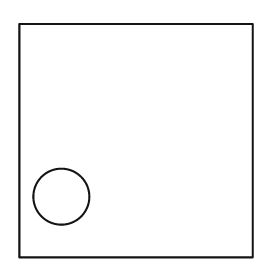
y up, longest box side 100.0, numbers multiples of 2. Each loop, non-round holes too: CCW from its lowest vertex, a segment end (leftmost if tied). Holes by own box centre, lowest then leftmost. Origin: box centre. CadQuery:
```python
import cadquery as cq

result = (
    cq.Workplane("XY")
    .moveTo(-50.0, -50.0)
    .lineTo(50.0, -50.0)
    .lineTo(50.0, 50.0)
    .lineTo(-50.0, 50.0)
    .close()
    .moveTo(-32.0, -24.0)
    .circle(12.0)
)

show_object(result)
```